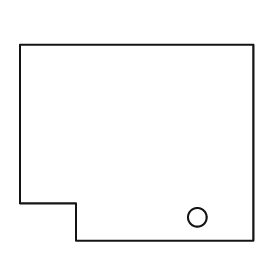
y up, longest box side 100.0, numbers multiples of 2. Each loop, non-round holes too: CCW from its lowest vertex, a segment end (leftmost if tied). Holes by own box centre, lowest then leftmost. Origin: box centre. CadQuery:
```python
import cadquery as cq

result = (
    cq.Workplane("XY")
    .moveTo(-26.0, -42.0)
    .lineTo(50.0, -42.0)
    .lineTo(50.0, 42.0)
    .lineTo(-50.0, 42.0)
    .lineTo(-50.0, -26.0)
    .lineTo(-26.0, -26.0)
    .close()
    .moveTo(26.0, -32.0)
    .circle(4.0)
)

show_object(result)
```